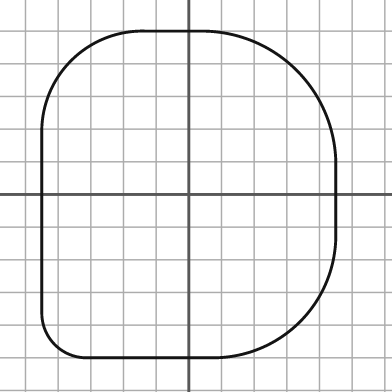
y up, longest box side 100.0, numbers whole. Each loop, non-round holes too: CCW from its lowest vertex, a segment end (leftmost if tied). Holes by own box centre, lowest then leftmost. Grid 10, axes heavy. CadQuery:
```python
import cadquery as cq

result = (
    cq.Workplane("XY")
    .moveTo(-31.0, -50.0)
    .lineTo(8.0, -50.0)
    .threePointArc((34.0, -39.0), (45.0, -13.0))
    .lineTo(45.0, 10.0)
    .threePointArc((33.0, 38.0), (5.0, 50.0))
    .lineTo(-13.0, 50.0)
    .threePointArc((-36.0, 41.0), (-45.0, 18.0))
    .lineTo(-45.0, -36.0)
    .threePointArc((-41.0, -46.0), (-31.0, -50.0))
    .close()
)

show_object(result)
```